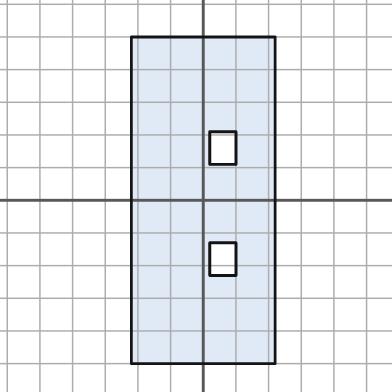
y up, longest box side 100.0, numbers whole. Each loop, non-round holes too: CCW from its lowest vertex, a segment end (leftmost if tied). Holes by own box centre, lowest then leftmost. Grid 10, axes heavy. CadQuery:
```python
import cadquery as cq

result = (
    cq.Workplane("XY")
    .moveTo(-22.0, -50.0)
    .lineTo(22.0, -50.0)
    .lineTo(22.0, 50.0)
    .lineTo(-22.0, 50.0)
    .close()
    .moveTo(2.0, -23.0)
    .lineTo(10.0, -23.0)
    .lineTo(10.0, -13.0)
    .lineTo(2.0, -13.0)
    .close()
    .moveTo(2.0, 11.0)
    .lineTo(10.0, 11.0)
    .lineTo(10.0, 21.0)
    .lineTo(2.0, 21.0)
    .close()
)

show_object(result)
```